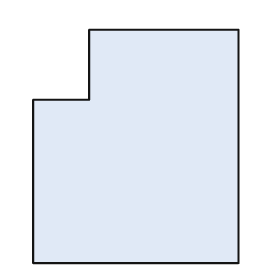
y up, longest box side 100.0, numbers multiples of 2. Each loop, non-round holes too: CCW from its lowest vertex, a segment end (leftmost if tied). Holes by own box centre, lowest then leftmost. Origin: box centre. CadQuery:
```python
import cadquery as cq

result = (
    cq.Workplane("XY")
    .moveTo(-44.0, -50.0)
    .lineTo(44.0, -50.0)
    .lineTo(44.0, 50.0)
    .lineTo(-20.0, 50.0)
    .lineTo(-20.0, 20.0)
    .lineTo(-44.0, 20.0)
    .close()
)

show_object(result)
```